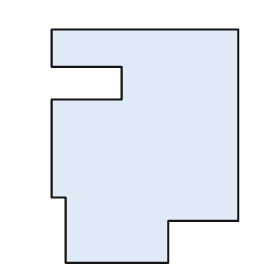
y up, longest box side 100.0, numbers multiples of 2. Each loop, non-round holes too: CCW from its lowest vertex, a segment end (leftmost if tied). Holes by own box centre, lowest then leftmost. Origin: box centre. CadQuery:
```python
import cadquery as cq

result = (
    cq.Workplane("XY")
    .moveTo(-34.0, -50.0)
    .lineTo(10.0, -50.0)
    .lineTo(10.0, -32.0)
    .lineTo(40.0, -32.0)
    .lineTo(40.0, 50.0)
    .lineTo(-40.0, 50.0)
    .lineTo(-40.0, 34.0)
    .lineTo(-10.0, 34.0)
    .lineTo(-10.0, 20.0)
    .lineTo(-40.0, 20.0)
    .lineTo(-40.0, -22.0)
    .lineTo(-34.0, -22.0)
    .close()
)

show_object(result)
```